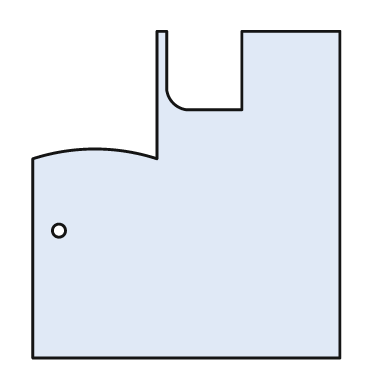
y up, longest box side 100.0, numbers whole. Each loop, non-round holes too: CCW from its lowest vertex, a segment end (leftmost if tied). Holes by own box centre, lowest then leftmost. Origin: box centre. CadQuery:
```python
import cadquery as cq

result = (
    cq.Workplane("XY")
    .moveTo(-47.0, -50.0)
    .lineTo(47.0, -50.0)
    .lineTo(47.0, 50.0)
    .lineTo(17.0, 50.0)
    .lineTo(17.0, 26.0)
    .lineTo(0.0, 26.0)
    .threePointArc((-4.0, 28.0), (-6.0, 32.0))
    .lineTo(-6.0, 50.0)
    .lineTo(-9.0, 50.0)
    .lineTo(-9.0, 11.0)
    .threePointArc((-28.0, 14.0), (-47.0, 11.0))
    .close()
    .moveTo(-39.0, -11.0)
    .circle(2.0)
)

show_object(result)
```